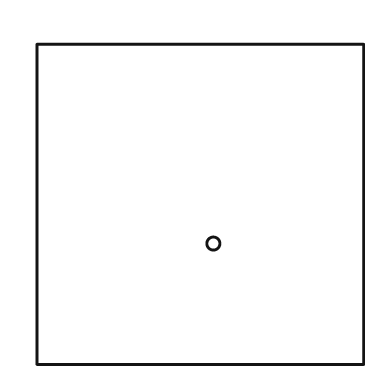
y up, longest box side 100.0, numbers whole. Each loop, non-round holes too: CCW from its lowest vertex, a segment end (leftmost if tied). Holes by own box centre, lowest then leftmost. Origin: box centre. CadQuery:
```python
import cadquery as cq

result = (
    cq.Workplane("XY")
    .moveTo(-50.0, -49.0)
    .lineTo(50.0, -49.0)
    .lineTo(50.0, 49.0)
    .lineTo(-50.0, 49.0)
    .close()
    .moveTo(4.0, -12.0)
    .circle(2.0)
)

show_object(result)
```